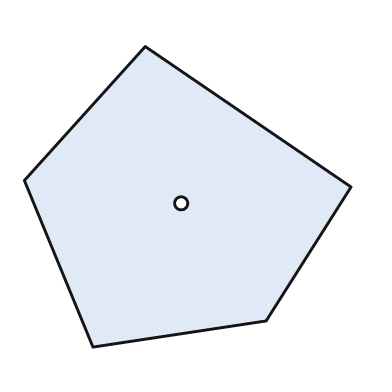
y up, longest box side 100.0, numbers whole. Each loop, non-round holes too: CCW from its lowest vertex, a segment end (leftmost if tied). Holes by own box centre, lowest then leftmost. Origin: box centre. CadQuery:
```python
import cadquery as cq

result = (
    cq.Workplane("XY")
    .moveTo(-29.0, -46.0)
    .lineTo(24.0, -38.0)
    .lineTo(50.0, 3.0)
    .lineTo(-13.0, 46.0)
    .lineTo(-50.0, 5.0)
    .close()
    .moveTo(-2.0, -2.0)
    .circle(2.0)
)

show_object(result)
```